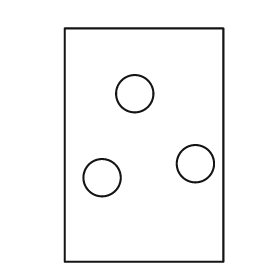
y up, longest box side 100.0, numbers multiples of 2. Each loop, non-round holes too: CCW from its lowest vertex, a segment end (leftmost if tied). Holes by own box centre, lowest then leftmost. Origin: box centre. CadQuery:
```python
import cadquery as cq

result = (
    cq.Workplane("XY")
    .moveTo(-34.0, -50.0)
    .lineTo(34.0, -50.0)
    .lineTo(34.0, 50.0)
    .lineTo(-34.0, 50.0)
    .close()
    .moveTo(-18.0, -14.0)
    .circle(8.0)
    .moveTo(22.0, -8.0)
    .circle(8.0)
    .moveTo(-4.0, 22.0)
    .circle(8.0)
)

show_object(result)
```